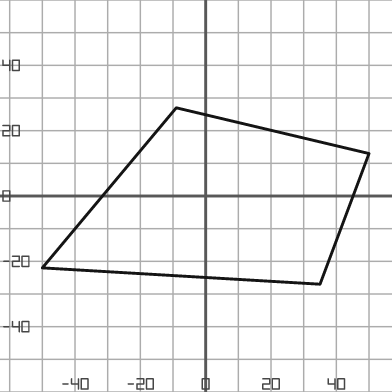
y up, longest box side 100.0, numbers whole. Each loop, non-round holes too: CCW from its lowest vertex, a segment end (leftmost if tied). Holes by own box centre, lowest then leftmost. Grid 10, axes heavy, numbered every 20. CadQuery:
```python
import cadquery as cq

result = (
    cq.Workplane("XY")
    .moveTo(35.0, -27.0)
    .lineTo(50.0, 13.0)
    .lineTo(-9.0, 27.0)
    .lineTo(-50.0, -22.0)
    .close()
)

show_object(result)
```